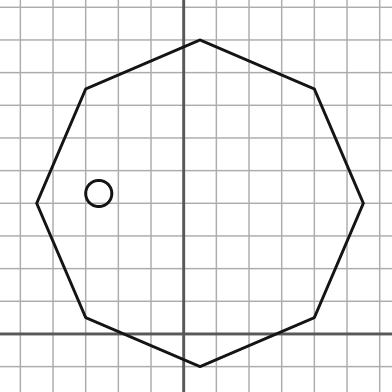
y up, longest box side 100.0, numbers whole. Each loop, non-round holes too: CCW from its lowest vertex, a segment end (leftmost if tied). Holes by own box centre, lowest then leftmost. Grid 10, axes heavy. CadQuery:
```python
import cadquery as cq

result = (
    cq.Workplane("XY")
    .moveTo(5.0, -10.0)
    .lineTo(40.0, 5.0)
    .lineTo(55.0, 40.0)
    .lineTo(40.0, 75.0)
    .lineTo(5.0, 90.0)
    .lineTo(-30.0, 75.0)
    .lineTo(-45.0, 40.0)
    .lineTo(-30.0, 5.0)
    .close()
    .moveTo(-26.0, 43.0)
    .circle(4.0)
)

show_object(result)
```